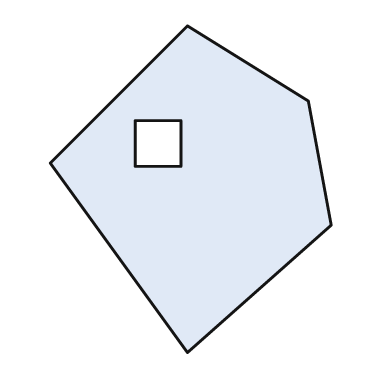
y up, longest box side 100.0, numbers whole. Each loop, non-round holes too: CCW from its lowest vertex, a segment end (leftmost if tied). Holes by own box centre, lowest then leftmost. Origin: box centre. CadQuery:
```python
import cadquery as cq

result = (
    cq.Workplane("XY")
    .moveTo(-1.0, -50.0)
    .lineTo(43.0, -11.0)
    .lineTo(36.0, 27.0)
    .lineTo(-1.0, 50.0)
    .lineTo(-43.0, 8.0)
    .close()
    .moveTo(-17.0, 7.0)
    .lineTo(-3.0, 7.0)
    .lineTo(-3.0, 21.0)
    .lineTo(-17.0, 21.0)
    .close()
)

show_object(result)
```